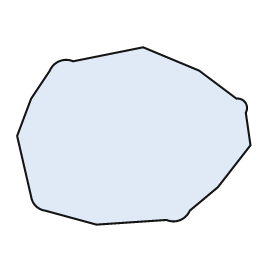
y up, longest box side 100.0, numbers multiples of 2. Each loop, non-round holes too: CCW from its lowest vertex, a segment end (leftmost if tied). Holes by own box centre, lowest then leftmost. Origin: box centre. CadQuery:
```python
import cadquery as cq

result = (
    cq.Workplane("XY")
    .moveTo(-16.0, -38.0)
    .lineTo(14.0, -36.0)
    .threePointArc((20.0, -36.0), (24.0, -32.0))
    .lineTo(36.0, -22.0)
    .lineTo(50.0, -4.0)
    .lineTo(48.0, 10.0)
    .threePointArc((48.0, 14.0), (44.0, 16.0))
    .lineTo(28.0, 28.0)
    .lineTo(4.0, 38.0)
    .lineTo(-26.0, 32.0)
    .threePointArc((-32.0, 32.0), (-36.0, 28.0))
    .lineTo(-44.0, 16.0)
    .lineTo(-50.0, 0.0)
    .lineTo(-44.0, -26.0)
    .threePointArc((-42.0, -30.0), (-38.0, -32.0))
    .close()
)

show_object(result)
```